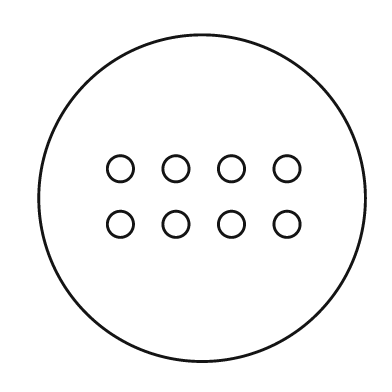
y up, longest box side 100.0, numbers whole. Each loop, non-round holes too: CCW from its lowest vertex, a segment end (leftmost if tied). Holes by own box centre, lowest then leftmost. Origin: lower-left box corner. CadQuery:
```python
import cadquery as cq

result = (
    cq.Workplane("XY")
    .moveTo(50.0, 50.0)
    .circle(50.0)
    .moveTo(25.0, 42.0)
    .circle(4.0)
    .moveTo(42.0, 42.0)
    .circle(4.0)
    .moveTo(59.0, 42.0)
    .circle(4.0)
    .moveTo(76.0, 42.0)
    .circle(4.0)
    .moveTo(25.0, 59.0)
    .circle(4.0)
    .moveTo(42.0, 59.0)
    .circle(4.0)
    .moveTo(59.0, 59.0)
    .circle(4.0)
    .moveTo(76.0, 59.0)
    .circle(4.0)
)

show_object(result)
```